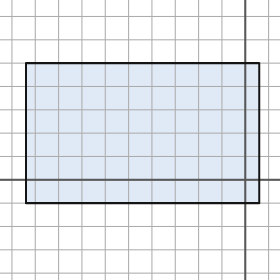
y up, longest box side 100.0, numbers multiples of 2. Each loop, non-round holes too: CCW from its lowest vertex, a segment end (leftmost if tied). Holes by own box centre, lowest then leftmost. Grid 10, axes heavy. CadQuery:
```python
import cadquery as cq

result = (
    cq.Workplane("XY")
    .moveTo(-94.0, -10.0)
    .lineTo(6.0, -10.0)
    .lineTo(6.0, 50.0)
    .lineTo(-94.0, 50.0)
    .close()
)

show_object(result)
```